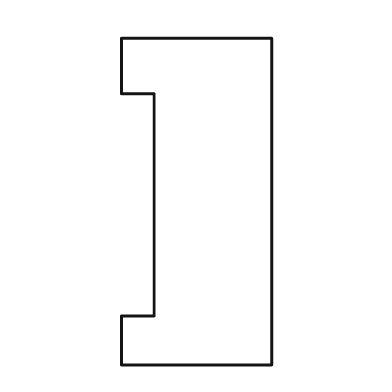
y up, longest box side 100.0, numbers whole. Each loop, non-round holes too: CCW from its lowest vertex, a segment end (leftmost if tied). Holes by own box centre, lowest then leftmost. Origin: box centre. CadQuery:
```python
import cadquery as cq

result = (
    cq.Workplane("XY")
    .moveTo(-23.0, -50.0)
    .lineTo(23.0, -50.0)
    .lineTo(23.0, 50.0)
    .lineTo(-23.0, 50.0)
    .lineTo(-23.0, 33.0)
    .lineTo(-13.0, 33.0)
    .lineTo(-13.0, -35.0)
    .lineTo(-23.0, -35.0)
    .close()
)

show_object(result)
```